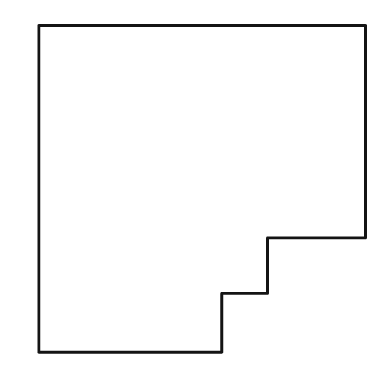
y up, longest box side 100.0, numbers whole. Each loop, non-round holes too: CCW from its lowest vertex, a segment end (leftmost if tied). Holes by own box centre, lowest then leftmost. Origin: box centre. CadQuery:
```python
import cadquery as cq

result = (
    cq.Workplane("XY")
    .moveTo(-50.0, -50.0)
    .lineTo(6.0, -50.0)
    .lineTo(6.0, -32.0)
    .lineTo(20.0, -32.0)
    .lineTo(20.0, -15.0)
    .lineTo(50.0, -15.0)
    .lineTo(50.0, 50.0)
    .lineTo(-50.0, 50.0)
    .close()
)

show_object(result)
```